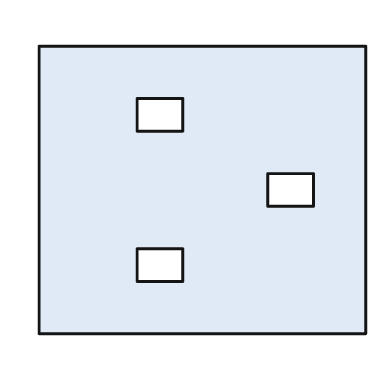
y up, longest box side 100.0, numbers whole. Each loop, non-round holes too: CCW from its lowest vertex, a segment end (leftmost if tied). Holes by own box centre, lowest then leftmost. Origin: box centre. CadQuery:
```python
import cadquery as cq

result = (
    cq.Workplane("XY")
    .moveTo(-50.0, -44.0)
    .lineTo(50.0, -44.0)
    .lineTo(50.0, 44.0)
    .lineTo(-50.0, 44.0)
    .close()
    .moveTo(-20.0, -28.0)
    .lineTo(-6.0, -28.0)
    .lineTo(-6.0, -18.0)
    .lineTo(-20.0, -18.0)
    .close()
    .moveTo(20.0, -5.0)
    .lineTo(34.0, -5.0)
    .lineTo(34.0, 5.0)
    .lineTo(20.0, 5.0)
    .close()
    .moveTo(-20.0, 18.0)
    .lineTo(-6.0, 18.0)
    .lineTo(-6.0, 28.0)
    .lineTo(-20.0, 28.0)
    .close()
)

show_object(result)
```